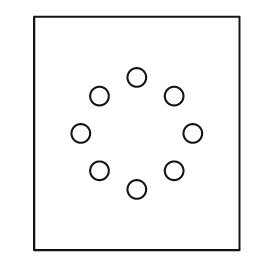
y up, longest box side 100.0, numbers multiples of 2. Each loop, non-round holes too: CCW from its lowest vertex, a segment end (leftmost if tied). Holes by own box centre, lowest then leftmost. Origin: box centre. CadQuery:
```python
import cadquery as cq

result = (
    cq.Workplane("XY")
    .moveTo(-44.0, -50.0)
    .lineTo(44.0, -50.0)
    .lineTo(44.0, 50.0)
    .lineTo(-44.0, 50.0)
    .close()
    .moveTo(0.0, -24.0)
    .circle(4.0)
    .moveTo(-16.0, -16.0)
    .circle(4.0)
    .moveTo(16.0, -16.0)
    .circle(4.0)
    .moveTo(-24.0, 0.0)
    .circle(4.0)
    .moveTo(24.0, 0.0)
    .circle(4.0)
    .moveTo(-16.0, 16.0)
    .circle(4.0)
    .moveTo(16.0, 16.0)
    .circle(4.0)
    .moveTo(0.0, 24.0)
    .circle(4.0)
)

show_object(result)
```